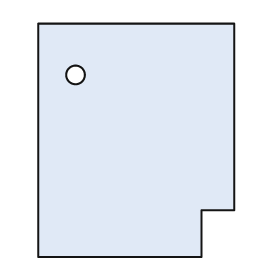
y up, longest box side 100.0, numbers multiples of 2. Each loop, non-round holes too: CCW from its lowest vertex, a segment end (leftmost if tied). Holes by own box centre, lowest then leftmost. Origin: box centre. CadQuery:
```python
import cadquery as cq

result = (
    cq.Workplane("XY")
    .moveTo(-42.0, -50.0)
    .lineTo(28.0, -50.0)
    .lineTo(28.0, -30.0)
    .lineTo(42.0, -30.0)
    .lineTo(42.0, 50.0)
    .lineTo(-42.0, 50.0)
    .close()
    .moveTo(-26.0, 28.0)
    .circle(4.0)
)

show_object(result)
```